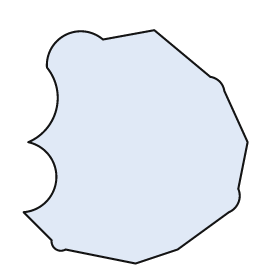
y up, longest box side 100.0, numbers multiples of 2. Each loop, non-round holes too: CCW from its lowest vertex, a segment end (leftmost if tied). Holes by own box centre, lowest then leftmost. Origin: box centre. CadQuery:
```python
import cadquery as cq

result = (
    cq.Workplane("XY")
    .moveTo(0.0, -50.0)
    .lineTo(18.0, -44.0)
    .lineTo(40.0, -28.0)
    .threePointArc((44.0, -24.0), (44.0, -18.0))
    .lineTo(48.0, 2.0)
    .lineTo(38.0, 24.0)
    .threePointArc((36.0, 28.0), (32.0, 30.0))
    .lineTo(8.0, 50.0)
    .lineTo(-14.0, 46.0)
    .threePointArc((-30.0, 48.0), (-38.0, 34.0))
    .threePointArc((-34.0, 16.0), (-46.0, 2.0))
    .threePointArc((-34.0, -14.0), (-48.0, -28.0))
    .lineTo(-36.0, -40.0)
    .threePointArc((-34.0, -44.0), (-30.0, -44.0))
    .close()
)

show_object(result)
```